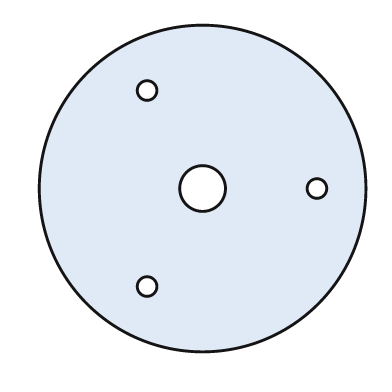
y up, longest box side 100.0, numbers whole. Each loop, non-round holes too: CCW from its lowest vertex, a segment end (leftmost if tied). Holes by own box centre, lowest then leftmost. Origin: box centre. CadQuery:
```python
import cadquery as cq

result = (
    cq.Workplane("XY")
    .moveTo(0.0, 0.0)
    .circle(50.0)
    .moveTo(-17.0, -30.0)
    .circle(3.0)
    .moveTo(0.0, 0.0)
    .circle(7.0)
    .moveTo(35.0, 0.0)
    .circle(3.0)
    .moveTo(-17.0, 30.0)
    .circle(3.0)
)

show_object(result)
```